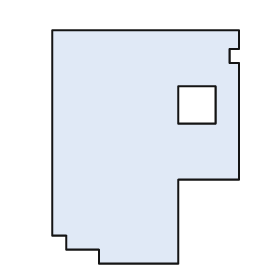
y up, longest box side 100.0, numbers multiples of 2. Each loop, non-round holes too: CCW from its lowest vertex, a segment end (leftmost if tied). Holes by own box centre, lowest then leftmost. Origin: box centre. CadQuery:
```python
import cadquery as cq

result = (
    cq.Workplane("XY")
    .moveTo(-20.0, -50.0)
    .lineTo(14.0, -50.0)
    .lineTo(14.0, -14.0)
    .lineTo(40.0, -14.0)
    .lineTo(40.0, 36.0)
    .lineTo(36.0, 36.0)
    .lineTo(36.0, 42.0)
    .lineTo(40.0, 42.0)
    .lineTo(40.0, 50.0)
    .lineTo(-40.0, 50.0)
    .lineTo(-40.0, -38.0)
    .lineTo(-34.0, -38.0)
    .lineTo(-34.0, -44.0)
    .lineTo(-20.0, -44.0)
    .close()
    .moveTo(14.0, 10.0)
    .lineTo(30.0, 10.0)
    .lineTo(30.0, 26.0)
    .lineTo(14.0, 26.0)
    .close()
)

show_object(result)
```